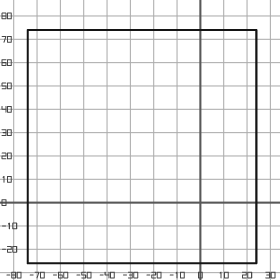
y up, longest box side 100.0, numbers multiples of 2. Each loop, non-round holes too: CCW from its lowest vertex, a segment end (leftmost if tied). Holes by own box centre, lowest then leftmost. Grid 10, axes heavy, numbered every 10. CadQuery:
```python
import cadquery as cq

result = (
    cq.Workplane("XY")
    .moveTo(-74.0, -26.0)
    .lineTo(24.0, -26.0)
    .lineTo(24.0, 74.0)
    .lineTo(-74.0, 74.0)
    .close()
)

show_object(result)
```